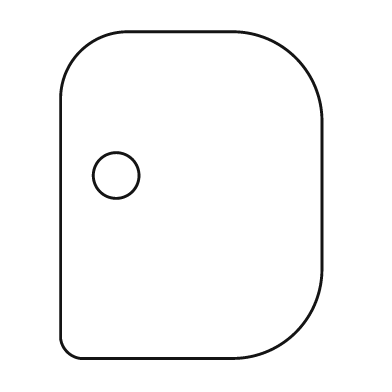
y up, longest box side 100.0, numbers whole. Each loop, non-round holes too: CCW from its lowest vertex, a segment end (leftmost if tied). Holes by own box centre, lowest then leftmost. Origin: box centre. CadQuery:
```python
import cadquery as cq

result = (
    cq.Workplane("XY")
    .moveTo(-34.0, -50.0)
    .lineTo(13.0, -50.0)
    .threePointArc((32.0, -42.0), (40.0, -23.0))
    .lineTo(40.0, 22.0)
    .threePointArc((32.0, 42.0), (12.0, 50.0))
    .lineTo(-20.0, 50.0)
    .threePointArc((-34.0, 44.0), (-40.0, 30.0))
    .lineTo(-40.0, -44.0)
    .threePointArc((-38.0, -48.0), (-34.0, -50.0))
    .close()
    .moveTo(-23.0, 6.0)
    .circle(7.0)
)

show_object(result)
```